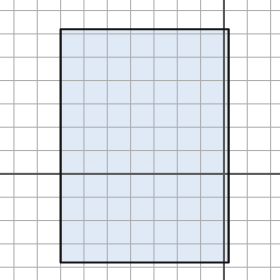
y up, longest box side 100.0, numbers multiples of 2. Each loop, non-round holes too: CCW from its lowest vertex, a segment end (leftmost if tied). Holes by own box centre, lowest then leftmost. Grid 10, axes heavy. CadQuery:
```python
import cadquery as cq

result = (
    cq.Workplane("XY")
    .moveTo(-70.0, -38.0)
    .lineTo(2.0, -38.0)
    .lineTo(2.0, 62.0)
    .lineTo(-70.0, 62.0)
    .close()
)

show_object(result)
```